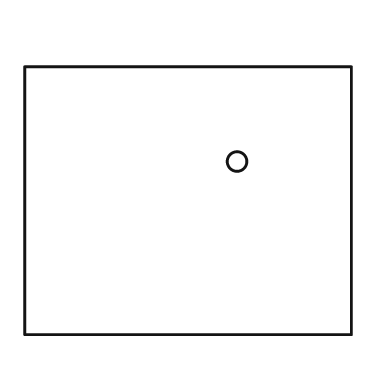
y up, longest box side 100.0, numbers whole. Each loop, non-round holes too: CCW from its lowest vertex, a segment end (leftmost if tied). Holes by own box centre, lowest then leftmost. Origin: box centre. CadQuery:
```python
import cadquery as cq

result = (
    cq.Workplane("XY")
    .moveTo(-50.0, -41.0)
    .lineTo(50.0, -41.0)
    .lineTo(50.0, 41.0)
    .lineTo(-50.0, 41.0)
    .close()
    .moveTo(15.0, 12.0)
    .circle(3.0)
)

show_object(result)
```